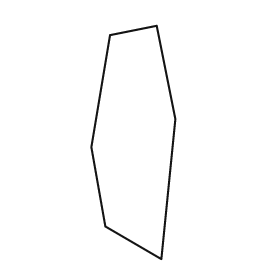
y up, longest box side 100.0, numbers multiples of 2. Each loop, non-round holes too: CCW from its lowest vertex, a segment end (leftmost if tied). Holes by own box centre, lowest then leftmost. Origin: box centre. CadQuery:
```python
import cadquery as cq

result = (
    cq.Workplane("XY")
    .moveTo(12.0, -50.0)
    .lineTo(18.0, 10.0)
    .lineTo(10.0, 50.0)
    .lineTo(-10.0, 46.0)
    .lineTo(-18.0, -2.0)
    .lineTo(-12.0, -36.0)
    .close()
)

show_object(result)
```